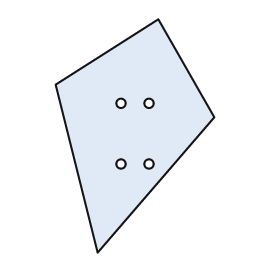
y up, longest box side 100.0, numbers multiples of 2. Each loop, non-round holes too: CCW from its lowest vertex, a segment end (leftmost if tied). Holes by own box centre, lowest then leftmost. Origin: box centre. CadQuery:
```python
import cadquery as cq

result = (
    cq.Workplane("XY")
    .moveTo(-16.0, -50.0)
    .lineTo(34.0, 8.0)
    .lineTo(10.0, 50.0)
    .lineTo(-34.0, 22.0)
    .close()
    .moveTo(-6.0, -12.0)
    .circle(2.0)
    .moveTo(6.0, -12.0)
    .circle(2.0)
    .moveTo(-6.0, 14.0)
    .circle(2.0)
    .moveTo(6.0, 14.0)
    .circle(2.0)
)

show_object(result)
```